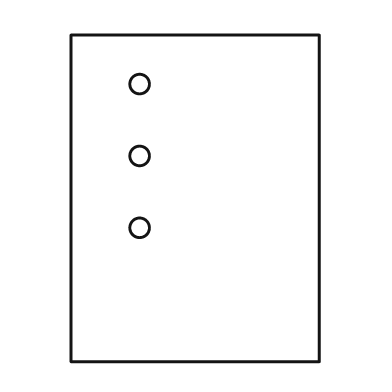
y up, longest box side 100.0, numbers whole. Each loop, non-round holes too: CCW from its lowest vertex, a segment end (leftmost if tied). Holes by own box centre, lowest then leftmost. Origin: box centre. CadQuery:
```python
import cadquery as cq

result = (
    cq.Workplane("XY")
    .moveTo(-38.0, -50.0)
    .lineTo(38.0, -50.0)
    .lineTo(38.0, 50.0)
    .lineTo(-38.0, 50.0)
    .close()
    .moveTo(-17.0, -9.0)
    .circle(3.0)
    .moveTo(-17.0, 13.0)
    .circle(3.0)
    .moveTo(-17.0, 35.0)
    .circle(3.0)
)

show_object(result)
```